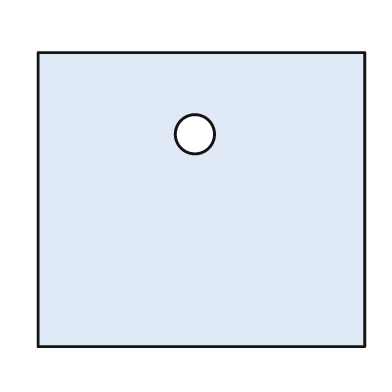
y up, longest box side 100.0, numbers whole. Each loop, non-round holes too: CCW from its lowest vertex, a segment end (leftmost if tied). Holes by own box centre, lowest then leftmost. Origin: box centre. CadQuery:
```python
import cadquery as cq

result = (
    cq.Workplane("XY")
    .moveTo(-50.0, -45.0)
    .lineTo(50.0, -45.0)
    .lineTo(50.0, 45.0)
    .lineTo(-50.0, 45.0)
    .close()
    .moveTo(-2.0, 20.0)
    .circle(6.0)
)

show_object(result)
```